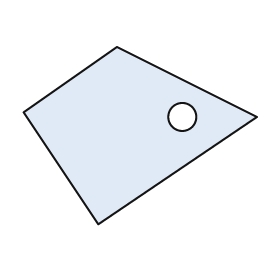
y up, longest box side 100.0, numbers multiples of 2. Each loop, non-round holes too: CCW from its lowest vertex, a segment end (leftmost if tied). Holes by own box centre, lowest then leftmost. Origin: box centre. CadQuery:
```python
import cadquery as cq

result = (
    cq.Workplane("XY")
    .moveTo(-18.0, -38.0)
    .lineTo(50.0, 8.0)
    .lineTo(-10.0, 38.0)
    .lineTo(-50.0, 10.0)
    .close()
    .moveTo(18.0, 8.0)
    .circle(6.0)
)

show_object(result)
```